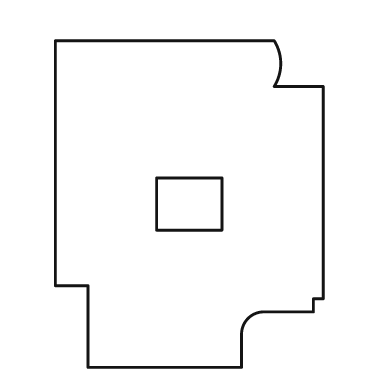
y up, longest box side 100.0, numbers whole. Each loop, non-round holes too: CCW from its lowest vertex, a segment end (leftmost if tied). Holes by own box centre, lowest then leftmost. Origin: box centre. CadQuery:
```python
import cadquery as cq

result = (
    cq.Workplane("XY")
    .moveTo(-31.0, -50.0)
    .lineTo(16.0, -50.0)
    .lineTo(16.0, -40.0)
    .threePointArc((18.0, -35.0), (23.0, -33.0))
    .lineTo(38.0, -33.0)
    .lineTo(38.0, -29.0)
    .lineTo(41.0, -29.0)
    .lineTo(41.0, 36.0)
    .lineTo(26.0, 36.0)
    .threePointArc((28.0, 43.0), (26.0, 50.0))
    .lineTo(-41.0, 50.0)
    .lineTo(-41.0, -25.0)
    .lineTo(-31.0, -25.0)
    .close()
    .moveTo(-10.0, -8.0)
    .lineTo(10.0, -8.0)
    .lineTo(10.0, 8.0)
    .lineTo(-10.0, 8.0)
    .close()
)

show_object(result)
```